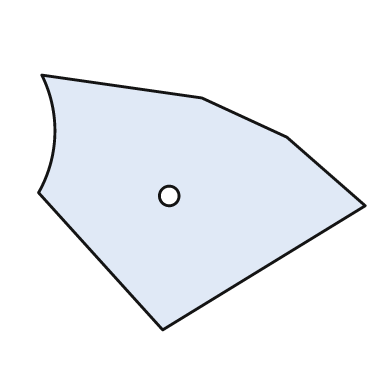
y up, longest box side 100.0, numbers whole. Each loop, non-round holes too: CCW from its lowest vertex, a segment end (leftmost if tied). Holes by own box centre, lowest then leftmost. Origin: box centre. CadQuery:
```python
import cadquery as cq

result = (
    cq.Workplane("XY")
    .moveTo(-12.0, -39.0)
    .lineTo(50.0, -1.0)
    .lineTo(26.0, 20.0)
    .lineTo(0.0, 32.0)
    .lineTo(-49.0, 39.0)
    .threePointArc((-45.0, 21.0), (-50.0, 3.0))
    .close()
    .moveTo(-10.0, 2.0)
    .circle(3.0)
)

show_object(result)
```